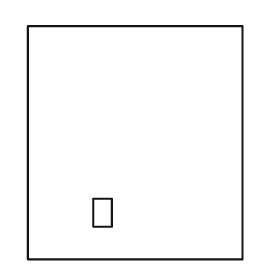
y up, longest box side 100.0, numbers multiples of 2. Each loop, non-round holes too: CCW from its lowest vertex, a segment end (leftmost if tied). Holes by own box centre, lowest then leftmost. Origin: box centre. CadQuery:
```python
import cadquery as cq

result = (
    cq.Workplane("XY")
    .moveTo(-46.0, -50.0)
    .lineTo(46.0, -50.0)
    .lineTo(46.0, 50.0)
    .lineTo(-46.0, 50.0)
    .close()
    .moveTo(-18.0, -36.0)
    .lineTo(-10.0, -36.0)
    .lineTo(-10.0, -24.0)
    .lineTo(-18.0, -24.0)
    .close()
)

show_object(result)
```